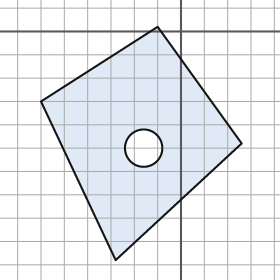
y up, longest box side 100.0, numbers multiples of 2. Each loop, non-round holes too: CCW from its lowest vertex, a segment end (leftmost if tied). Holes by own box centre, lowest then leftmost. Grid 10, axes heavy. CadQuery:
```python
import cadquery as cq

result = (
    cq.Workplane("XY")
    .moveTo(-28.0, -98.0)
    .lineTo(26.0, -48.0)
    .lineTo(-10.0, 2.0)
    .lineTo(-60.0, -30.0)
    .close()
    .moveTo(-16.0, -50.0)
    .circle(8.0)
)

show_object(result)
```